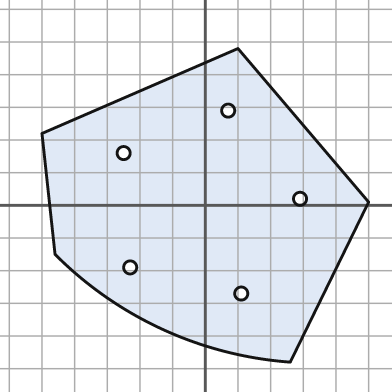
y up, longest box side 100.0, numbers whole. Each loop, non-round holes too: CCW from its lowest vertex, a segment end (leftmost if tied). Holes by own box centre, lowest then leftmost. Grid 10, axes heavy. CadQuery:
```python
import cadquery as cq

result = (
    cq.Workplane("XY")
    .moveTo(26.0, -48.0)
    .lineTo(50.0, 1.0)
    .lineTo(10.0, 48.0)
    .lineTo(-50.0, 22.0)
    .lineTo(-46.0, -15.0)
    .threePointArc((-13.0, -38.0), (26.0, -48.0))
    .close()
    .moveTo(11.0, -27.0)
    .circle(2.0)
    .moveTo(-23.0, -19.0)
    .circle(2.0)
    .moveTo(29.0, 2.0)
    .circle(2.0)
    .moveTo(-25.0, 16.0)
    .circle(2.0)
    .moveTo(7.0, 29.0)
    .circle(2.0)
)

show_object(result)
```